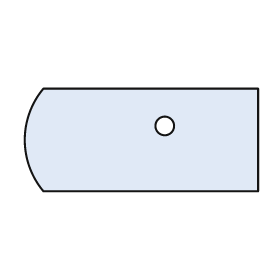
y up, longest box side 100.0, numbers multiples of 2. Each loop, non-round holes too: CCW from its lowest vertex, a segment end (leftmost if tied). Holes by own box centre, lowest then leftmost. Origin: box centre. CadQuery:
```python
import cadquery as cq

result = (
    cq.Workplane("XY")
    .moveTo(-42.0, -22.0)
    .lineTo(50.0, -22.0)
    .lineTo(50.0, 22.0)
    .lineTo(-42.0, 22.0)
    .threePointArc((-50.0, 0.0), (-42.0, -22.0))
    .close()
    .moveTo(10.0, 6.0)
    .circle(4.0)
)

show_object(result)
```